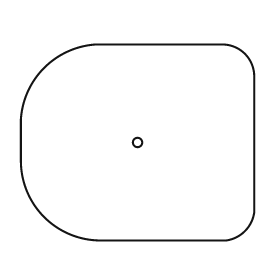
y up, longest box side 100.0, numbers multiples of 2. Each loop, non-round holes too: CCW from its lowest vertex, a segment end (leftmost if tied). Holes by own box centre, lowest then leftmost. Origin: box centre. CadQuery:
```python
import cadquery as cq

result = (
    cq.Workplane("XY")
    .moveTo(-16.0, -42.0)
    .lineTo(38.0, -42.0)
    .threePointArc((46.0, -38.0), (50.0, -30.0))
    .lineTo(50.0, 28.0)
    .threePointArc((46.0, 38.0), (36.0, 42.0))
    .lineTo(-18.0, 42.0)
    .threePointArc((-40.0, 32.0), (-50.0, 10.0))
    .lineTo(-50.0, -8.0)
    .threePointArc((-40.0, -32.0), (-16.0, -42.0))
    .close()
    .moveTo(0.0, 0.0)
    .circle(2.0)
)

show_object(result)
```